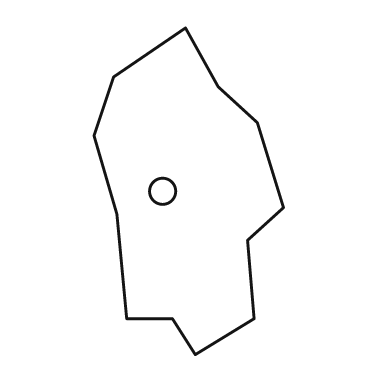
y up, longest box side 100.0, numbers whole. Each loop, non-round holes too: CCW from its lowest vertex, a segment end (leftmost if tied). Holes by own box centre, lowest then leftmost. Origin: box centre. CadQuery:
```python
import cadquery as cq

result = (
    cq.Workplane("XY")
    .moveTo(2.0, -50.0)
    .lineTo(20.0, -39.0)
    .lineTo(18.0, -15.0)
    .lineTo(29.0, -5.0)
    .lineTo(21.0, 21.0)
    .lineTo(9.0, 32.0)
    .lineTo(-1.0, 50.0)
    .lineTo(-23.0, 35.0)
    .lineTo(-29.0, 17.0)
    .lineTo(-22.0, -7.0)
    .lineTo(-19.0, -39.0)
    .lineTo(-5.0, -39.0)
    .close()
    .moveTo(-8.0, 0.0)
    .circle(4.0)
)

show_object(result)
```